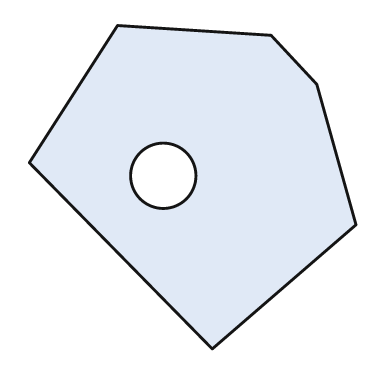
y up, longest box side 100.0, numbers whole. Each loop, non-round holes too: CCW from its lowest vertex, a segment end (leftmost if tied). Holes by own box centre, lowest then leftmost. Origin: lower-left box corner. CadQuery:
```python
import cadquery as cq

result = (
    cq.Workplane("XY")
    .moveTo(56.0, 0.0)
    .lineTo(100.0, 38.0)
    .lineTo(88.0, 81.0)
    .lineTo(74.0, 96.0)
    .lineTo(27.0, 99.0)
    .lineTo(0.0, 57.0)
    .close()
    .moveTo(41.0, 53.0)
    .circle(10.0)
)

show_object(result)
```